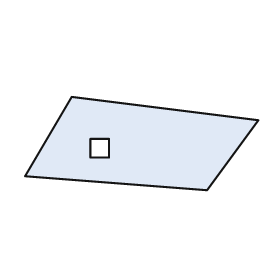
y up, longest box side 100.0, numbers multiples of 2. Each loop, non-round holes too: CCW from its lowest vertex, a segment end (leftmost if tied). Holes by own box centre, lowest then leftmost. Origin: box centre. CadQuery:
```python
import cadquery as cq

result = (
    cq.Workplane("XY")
    .moveTo(28.0, -20.0)
    .lineTo(50.0, 10.0)
    .lineTo(-30.0, 20.0)
    .lineTo(-50.0, -14.0)
    .close()
    .moveTo(-22.0, -6.0)
    .lineTo(-14.0, -6.0)
    .lineTo(-14.0, 2.0)
    .lineTo(-22.0, 2.0)
    .close()
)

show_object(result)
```